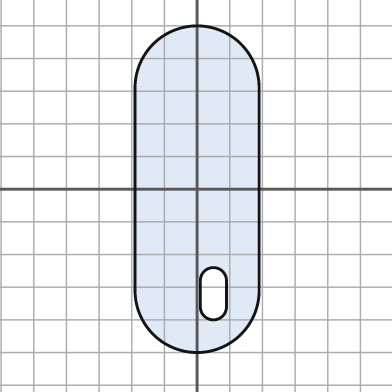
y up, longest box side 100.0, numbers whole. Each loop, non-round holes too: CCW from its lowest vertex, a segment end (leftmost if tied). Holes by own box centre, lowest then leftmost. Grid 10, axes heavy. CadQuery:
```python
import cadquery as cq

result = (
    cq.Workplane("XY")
    .moveTo(-19.0, -31.0)
    .threePointArc((0.0, -50.0), (19.0, -31.0))
    .lineTo(19.0, 31.0)
    .threePointArc((0.0, 50.0), (-19.0, 31.0))
    .close()
    .moveTo(1.0, -36.0)
    .threePointArc((5.0, -40.0), (9.0, -36.0))
    .lineTo(9.0, -28.0)
    .threePointArc((5.0, -24.0), (1.0, -28.0))
    .close()
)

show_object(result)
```